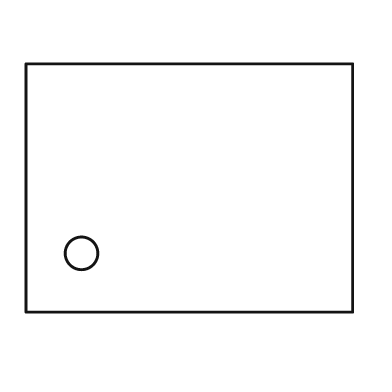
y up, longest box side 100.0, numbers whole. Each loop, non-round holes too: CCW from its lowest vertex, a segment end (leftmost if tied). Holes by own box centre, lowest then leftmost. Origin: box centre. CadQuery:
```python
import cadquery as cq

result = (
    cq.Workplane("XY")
    .moveTo(-50.0, -38.0)
    .lineTo(50.0, -38.0)
    .lineTo(50.0, 38.0)
    .lineTo(-50.0, 38.0)
    .close()
    .moveTo(-33.0, -20.0)
    .circle(5.0)
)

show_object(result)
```